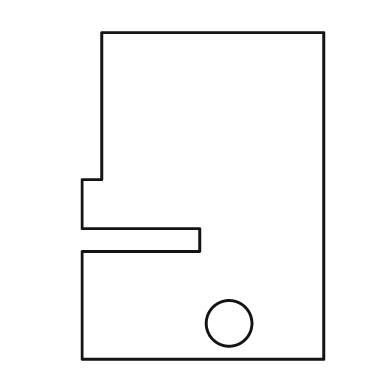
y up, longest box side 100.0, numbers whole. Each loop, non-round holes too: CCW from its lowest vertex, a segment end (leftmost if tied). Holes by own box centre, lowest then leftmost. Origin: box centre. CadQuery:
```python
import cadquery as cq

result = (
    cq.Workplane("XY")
    .moveTo(-37.0, -50.0)
    .lineTo(37.0, -50.0)
    .lineTo(37.0, 50.0)
    .lineTo(-31.0, 50.0)
    .lineTo(-31.0, 5.0)
    .lineTo(-37.0, 5.0)
    .lineTo(-37.0, -10.0)
    .lineTo(-1.0, -10.0)
    .lineTo(-1.0, -17.0)
    .lineTo(-37.0, -17.0)
    .close()
    .moveTo(8.0, -39.0)
    .circle(7.0)
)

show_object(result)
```